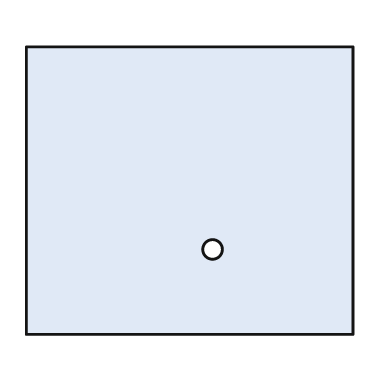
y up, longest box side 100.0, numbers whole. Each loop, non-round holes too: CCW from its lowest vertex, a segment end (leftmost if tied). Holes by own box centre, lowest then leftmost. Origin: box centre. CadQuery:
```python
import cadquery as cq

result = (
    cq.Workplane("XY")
    .moveTo(-50.0, -44.0)
    .lineTo(50.0, -44.0)
    .lineTo(50.0, 44.0)
    .lineTo(-50.0, 44.0)
    .close()
    .moveTo(7.0, -18.0)
    .circle(3.0)
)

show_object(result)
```